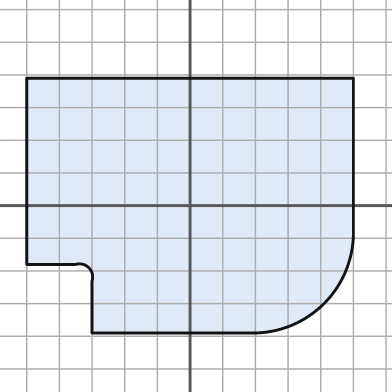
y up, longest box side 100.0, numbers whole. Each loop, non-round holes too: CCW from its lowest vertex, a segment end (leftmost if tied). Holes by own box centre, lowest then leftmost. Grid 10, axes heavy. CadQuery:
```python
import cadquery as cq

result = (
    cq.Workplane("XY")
    .moveTo(-30.0, -39.0)
    .lineTo(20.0, -39.0)
    .threePointArc((41.0, -30.0), (50.0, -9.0))
    .lineTo(50.0, 39.0)
    .lineTo(-50.0, 39.0)
    .lineTo(-50.0, -18.0)
    .lineTo(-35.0, -18.0)
    .threePointArc((-31.0, -19.0), (-30.0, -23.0))
    .close()
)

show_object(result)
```